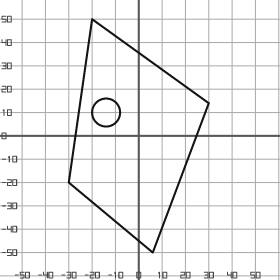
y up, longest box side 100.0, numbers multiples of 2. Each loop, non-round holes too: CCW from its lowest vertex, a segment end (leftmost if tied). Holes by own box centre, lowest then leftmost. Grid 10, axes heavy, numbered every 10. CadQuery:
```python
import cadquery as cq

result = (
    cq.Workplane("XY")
    .moveTo(6.0, -50.0)
    .lineTo(30.0, 14.0)
    .lineTo(-20.0, 50.0)
    .lineTo(-30.0, -20.0)
    .close()
    .moveTo(-14.0, 10.0)
    .circle(6.0)
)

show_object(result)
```